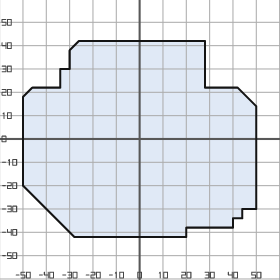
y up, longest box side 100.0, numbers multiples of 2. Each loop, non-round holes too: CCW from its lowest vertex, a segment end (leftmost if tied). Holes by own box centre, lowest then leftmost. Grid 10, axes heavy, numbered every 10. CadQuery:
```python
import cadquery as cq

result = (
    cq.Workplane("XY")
    .moveTo(-28.0, -42.0)
    .lineTo(20.0, -42.0)
    .lineTo(20.0, -38.0)
    .lineTo(40.0, -38.0)
    .lineTo(40.0, -34.0)
    .lineTo(44.0, -34.0)
    .lineTo(44.0, -30.0)
    .lineTo(50.0, -30.0)
    .lineTo(50.0, 14.0)
    .lineTo(42.0, 22.0)
    .lineTo(28.0, 22.0)
    .lineTo(28.0, 42.0)
    .lineTo(-26.0, 42.0)
    .lineTo(-30.0, 38.0)
    .lineTo(-30.0, 30.0)
    .lineTo(-34.0, 30.0)
    .lineTo(-34.0, 22.0)
    .lineTo(-46.0, 22.0)
    .lineTo(-50.0, 18.0)
    .lineTo(-50.0, -20.0)
    .close()
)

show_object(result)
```